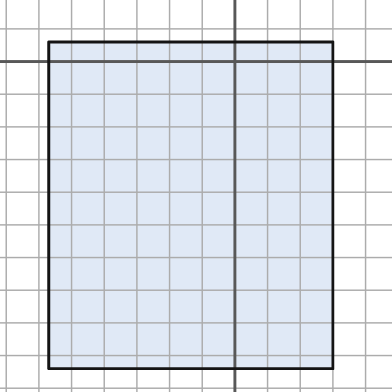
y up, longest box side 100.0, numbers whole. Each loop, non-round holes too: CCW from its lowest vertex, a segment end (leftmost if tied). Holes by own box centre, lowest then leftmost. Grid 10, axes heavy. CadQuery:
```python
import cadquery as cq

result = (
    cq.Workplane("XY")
    .moveTo(-57.0, -94.0)
    .lineTo(30.0, -94.0)
    .lineTo(30.0, 6.0)
    .lineTo(-57.0, 6.0)
    .close()
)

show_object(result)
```